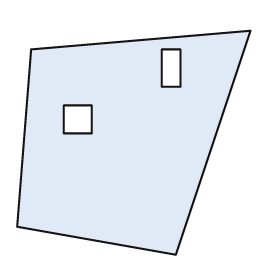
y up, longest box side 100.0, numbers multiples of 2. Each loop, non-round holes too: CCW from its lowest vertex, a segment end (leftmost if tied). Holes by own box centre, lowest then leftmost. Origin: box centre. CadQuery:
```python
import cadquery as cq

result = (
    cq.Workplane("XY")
    .moveTo(18.0, -48.0)
    .lineTo(50.0, 48.0)
    .lineTo(-44.0, 40.0)
    .lineTo(-50.0, -36.0)
    .close()
    .moveTo(-30.0, 4.0)
    .lineTo(-18.0, 4.0)
    .lineTo(-18.0, 16.0)
    .lineTo(-30.0, 16.0)
    .close()
    .moveTo(12.0, 24.0)
    .lineTo(20.0, 24.0)
    .lineTo(20.0, 40.0)
    .lineTo(12.0, 40.0)
    .close()
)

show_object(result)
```